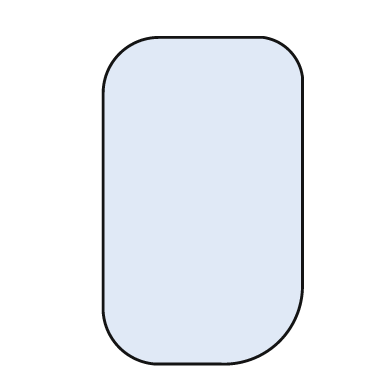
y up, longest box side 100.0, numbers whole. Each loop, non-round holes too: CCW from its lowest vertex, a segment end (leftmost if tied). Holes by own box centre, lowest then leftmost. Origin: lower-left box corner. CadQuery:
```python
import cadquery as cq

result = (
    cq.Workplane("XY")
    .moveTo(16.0, 0.0)
    .lineTo(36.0, 0.0)
    .threePointArc((54.0, 7.0), (61.0, 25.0))
    .lineTo(61.0, 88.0)
    .threePointArc((57.0, 96.0), (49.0, 100.0))
    .lineTo(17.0, 100.0)
    .threePointArc((5.0, 95.0), (0.0, 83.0))
    .lineTo(0.0, 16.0)
    .threePointArc((5.0, 5.0), (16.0, 0.0))
    .close()
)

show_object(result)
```